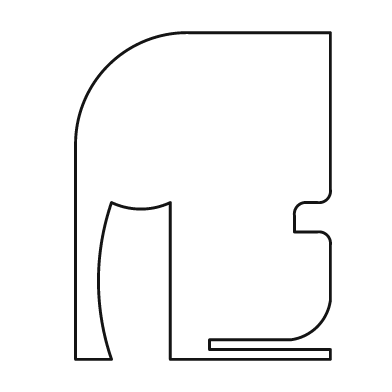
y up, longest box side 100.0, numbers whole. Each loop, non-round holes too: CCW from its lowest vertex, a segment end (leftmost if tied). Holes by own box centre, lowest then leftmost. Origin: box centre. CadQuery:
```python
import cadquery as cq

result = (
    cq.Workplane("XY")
    .moveTo(-39.0, -50.0)
    .lineTo(-28.0, -50.0)
    .threePointArc((-32.0, -26.0), (-28.0, -2.0))
    .threePointArc((-19.0, -4.0), (-10.0, -2.0))
    .lineTo(-10.0, -50.0)
    .lineTo(39.0, -50.0)
    .lineTo(39.0, -47.0)
    .lineTo(2.0, -47.0)
    .lineTo(2.0, -44.0)
    .lineTo(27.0, -44.0)
    .threePointArc((35.0, -40.0), (39.0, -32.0))
    .lineTo(39.0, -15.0)
    .threePointArc((38.0, -12.0), (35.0, -11.0))
    .lineTo(28.0, -11.0)
    .lineTo(28.0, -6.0)
    .threePointArc((29.0, -3.0), (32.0, -2.0))
    .lineTo(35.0, -2.0)
    .threePointArc((38.0, -1.0), (39.0, 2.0))
    .lineTo(39.0, 50.0)
    .lineTo(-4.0, 50.0)
    .threePointArc((-29.0, 40.0), (-39.0, 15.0))
    .close()
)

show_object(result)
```